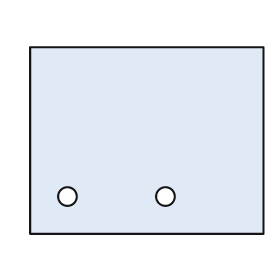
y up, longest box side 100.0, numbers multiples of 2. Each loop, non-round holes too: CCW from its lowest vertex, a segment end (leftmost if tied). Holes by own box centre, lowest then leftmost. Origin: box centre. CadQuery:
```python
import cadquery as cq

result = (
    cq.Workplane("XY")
    .moveTo(-50.0, -40.0)
    .lineTo(50.0, -40.0)
    .lineTo(50.0, 40.0)
    .lineTo(-50.0, 40.0)
    .close()
    .moveTo(-34.0, -24.0)
    .circle(4.0)
    .moveTo(8.0, -24.0)
    .circle(4.0)
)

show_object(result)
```